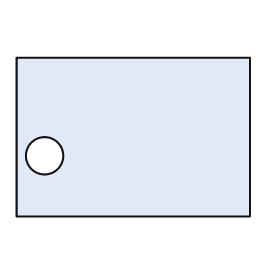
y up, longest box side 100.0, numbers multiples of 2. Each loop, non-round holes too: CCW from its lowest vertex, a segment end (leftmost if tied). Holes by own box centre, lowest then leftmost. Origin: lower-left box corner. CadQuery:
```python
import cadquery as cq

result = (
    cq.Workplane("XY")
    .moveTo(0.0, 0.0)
    .lineTo(100.0, 0.0)
    .lineTo(100.0, 68.0)
    .lineTo(0.0, 68.0)
    .close()
    .moveTo(12.0, 26.0)
    .circle(8.0)
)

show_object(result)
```